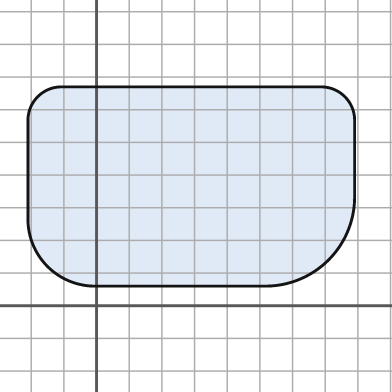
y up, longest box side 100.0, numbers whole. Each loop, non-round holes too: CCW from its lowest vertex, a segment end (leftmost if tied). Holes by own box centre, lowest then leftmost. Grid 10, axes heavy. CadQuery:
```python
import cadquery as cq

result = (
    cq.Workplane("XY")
    .moveTo(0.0, 6.0)
    .lineTo(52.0, 6.0)
    .threePointArc((71.0, 14.0), (79.0, 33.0))
    .lineTo(79.0, 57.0)
    .threePointArc((76.0, 64.0), (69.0, 67.0))
    .lineTo(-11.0, 67.0)
    .threePointArc((-18.0, 64.0), (-21.0, 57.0))
    .lineTo(-21.0, 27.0)
    .threePointArc((-15.0, 12.0), (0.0, 6.0))
    .close()
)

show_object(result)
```